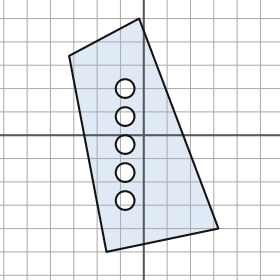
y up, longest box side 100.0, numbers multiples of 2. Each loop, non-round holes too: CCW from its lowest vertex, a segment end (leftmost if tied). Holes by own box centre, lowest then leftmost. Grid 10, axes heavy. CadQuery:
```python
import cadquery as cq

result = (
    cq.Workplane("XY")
    .moveTo(-16.0, -50.0)
    .lineTo(32.0, -40.0)
    .lineTo(-2.0, 50.0)
    .lineTo(-32.0, 34.0)
    .close()
    .moveTo(-8.0, -28.0)
    .circle(4.0)
    .moveTo(-8.0, -16.0)
    .circle(4.0)
    .moveTo(-8.0, -4.0)
    .circle(4.0)
    .moveTo(-8.0, 8.0)
    .circle(4.0)
    .moveTo(-8.0, 20.0)
    .circle(4.0)
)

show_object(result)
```